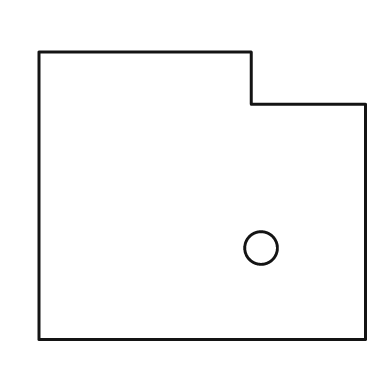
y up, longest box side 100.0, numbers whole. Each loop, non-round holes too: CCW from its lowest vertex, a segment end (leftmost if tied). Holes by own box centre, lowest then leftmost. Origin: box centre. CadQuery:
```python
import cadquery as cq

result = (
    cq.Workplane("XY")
    .moveTo(-50.0, -44.0)
    .lineTo(50.0, -44.0)
    .lineTo(50.0, 28.0)
    .lineTo(15.0, 28.0)
    .lineTo(15.0, 44.0)
    .lineTo(-50.0, 44.0)
    .close()
    .moveTo(18.0, -16.0)
    .circle(5.0)
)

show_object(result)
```